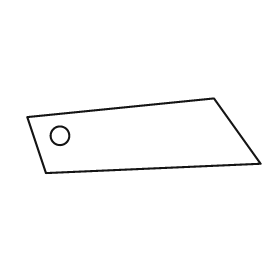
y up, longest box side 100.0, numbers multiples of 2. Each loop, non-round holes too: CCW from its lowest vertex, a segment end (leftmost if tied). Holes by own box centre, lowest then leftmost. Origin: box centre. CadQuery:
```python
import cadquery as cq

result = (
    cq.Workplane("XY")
    .moveTo(-42.0, -16.0)
    .lineTo(50.0, -12.0)
    .lineTo(30.0, 16.0)
    .lineTo(-50.0, 8.0)
    .close()
    .moveTo(-36.0, 0.0)
    .circle(4.0)
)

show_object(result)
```